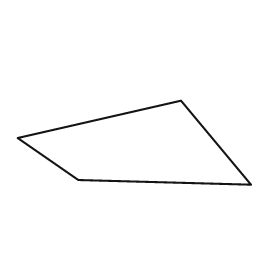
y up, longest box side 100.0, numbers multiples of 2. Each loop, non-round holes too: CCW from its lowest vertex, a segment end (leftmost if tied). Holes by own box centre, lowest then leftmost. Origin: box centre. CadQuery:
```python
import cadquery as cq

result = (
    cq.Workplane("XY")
    .moveTo(50.0, -18.0)
    .lineTo(20.0, 18.0)
    .lineTo(-50.0, 2.0)
    .lineTo(-24.0, -16.0)
    .close()
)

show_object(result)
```